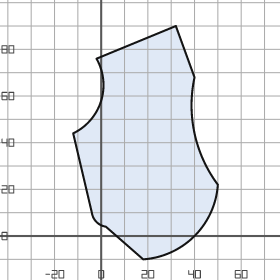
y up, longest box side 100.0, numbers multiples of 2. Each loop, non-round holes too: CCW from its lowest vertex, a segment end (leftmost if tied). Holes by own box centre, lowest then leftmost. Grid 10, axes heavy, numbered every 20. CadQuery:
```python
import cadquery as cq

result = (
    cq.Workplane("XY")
    .moveTo(18.0, -10.0)
    .threePointArc((40.0, 0.0), (50.0, 22.0))
    .threePointArc((40.0, 44.0), (40.0, 68.0))
    .lineTo(32.0, 90.0)
    .lineTo(-2.0, 76.0)
    .threePointArc((0.0, 58.0), (-12.0, 44.0))
    .lineTo(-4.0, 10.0)
    .threePointArc((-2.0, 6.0), (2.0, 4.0))
    .close()
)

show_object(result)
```